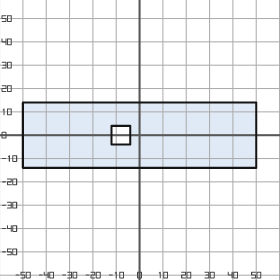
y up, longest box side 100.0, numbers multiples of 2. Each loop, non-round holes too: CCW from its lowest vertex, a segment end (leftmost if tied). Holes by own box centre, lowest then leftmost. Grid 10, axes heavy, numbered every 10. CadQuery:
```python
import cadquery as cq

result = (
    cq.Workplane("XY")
    .moveTo(-50.0, -14.0)
    .lineTo(50.0, -14.0)
    .lineTo(50.0, 14.0)
    .lineTo(-50.0, 14.0)
    .close()
    .moveTo(-12.0, -4.0)
    .lineTo(-4.0, -4.0)
    .lineTo(-4.0, 4.0)
    .lineTo(-12.0, 4.0)
    .close()
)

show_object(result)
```